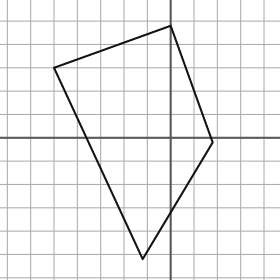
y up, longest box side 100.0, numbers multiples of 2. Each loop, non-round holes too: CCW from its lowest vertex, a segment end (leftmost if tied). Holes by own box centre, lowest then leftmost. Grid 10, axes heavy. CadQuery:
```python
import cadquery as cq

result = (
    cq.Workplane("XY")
    .moveTo(-12.0, -52.0)
    .lineTo(18.0, -2.0)
    .lineTo(0.0, 48.0)
    .lineTo(-50.0, 30.0)
    .close()
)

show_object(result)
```